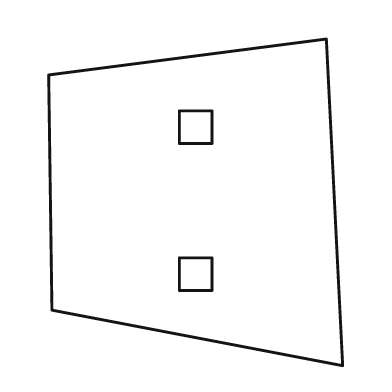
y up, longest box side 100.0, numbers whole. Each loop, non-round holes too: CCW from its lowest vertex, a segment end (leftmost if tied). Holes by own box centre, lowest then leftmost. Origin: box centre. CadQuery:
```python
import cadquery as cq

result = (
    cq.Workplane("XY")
    .moveTo(45.0, -50.0)
    .lineTo(40.0, 50.0)
    .lineTo(-45.0, 39.0)
    .lineTo(-44.0, -33.0)
    .close()
    .moveTo(-5.0, -27.0)
    .lineTo(5.0, -27.0)
    .lineTo(5.0, -17.0)
    .lineTo(-5.0, -17.0)
    .close()
    .moveTo(-5.0, 18.0)
    .lineTo(5.0, 18.0)
    .lineTo(5.0, 28.0)
    .lineTo(-5.0, 28.0)
    .close()
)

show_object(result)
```